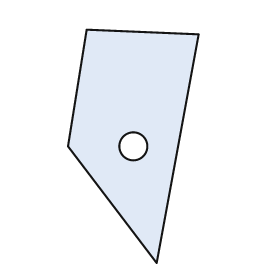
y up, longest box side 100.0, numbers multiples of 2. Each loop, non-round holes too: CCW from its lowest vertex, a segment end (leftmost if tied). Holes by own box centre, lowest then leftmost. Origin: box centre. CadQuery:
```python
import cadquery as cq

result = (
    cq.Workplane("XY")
    .moveTo(10.0, -50.0)
    .lineTo(28.0, 48.0)
    .lineTo(-20.0, 50.0)
    .lineTo(-28.0, 0.0)
    .close()
    .moveTo(0.0, 0.0)
    .circle(6.0)
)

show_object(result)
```